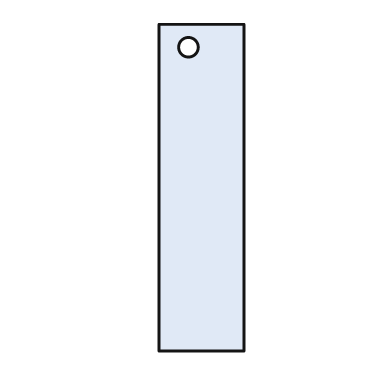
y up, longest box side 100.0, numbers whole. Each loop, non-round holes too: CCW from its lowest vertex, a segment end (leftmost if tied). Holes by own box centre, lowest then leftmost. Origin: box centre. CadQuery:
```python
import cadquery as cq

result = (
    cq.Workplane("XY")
    .moveTo(-13.0, -50.0)
    .lineTo(13.0, -50.0)
    .lineTo(13.0, 50.0)
    .lineTo(-13.0, 50.0)
    .close()
    .moveTo(-4.0, 43.0)
    .circle(3.0)
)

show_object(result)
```